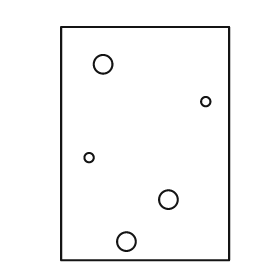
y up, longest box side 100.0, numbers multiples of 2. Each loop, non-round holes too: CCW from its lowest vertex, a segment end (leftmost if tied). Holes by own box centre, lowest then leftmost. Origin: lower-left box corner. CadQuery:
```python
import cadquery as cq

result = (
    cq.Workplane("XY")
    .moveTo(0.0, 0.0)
    .lineTo(72.0, 0.0)
    .lineTo(72.0, 100.0)
    .lineTo(0.0, 100.0)
    .close()
    .moveTo(28.0, 8.0)
    .circle(4.0)
    .moveTo(46.0, 26.0)
    .circle(4.0)
    .moveTo(12.0, 44.0)
    .circle(2.0)
    .moveTo(62.0, 68.0)
    .circle(2.0)
    .moveTo(18.0, 84.0)
    .circle(4.0)
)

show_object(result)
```